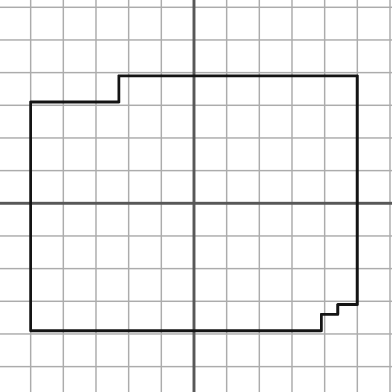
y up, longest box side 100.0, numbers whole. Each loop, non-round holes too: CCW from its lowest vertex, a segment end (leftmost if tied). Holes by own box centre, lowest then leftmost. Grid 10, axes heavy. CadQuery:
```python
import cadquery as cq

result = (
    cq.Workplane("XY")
    .moveTo(-50.0, -39.0)
    .lineTo(39.0, -39.0)
    .lineTo(39.0, -34.0)
    .lineTo(44.0, -34.0)
    .lineTo(44.0, -31.0)
    .lineTo(50.0, -31.0)
    .lineTo(50.0, 39.0)
    .lineTo(-23.0, 39.0)
    .lineTo(-23.0, 31.0)
    .lineTo(-50.0, 31.0)
    .close()
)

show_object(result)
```